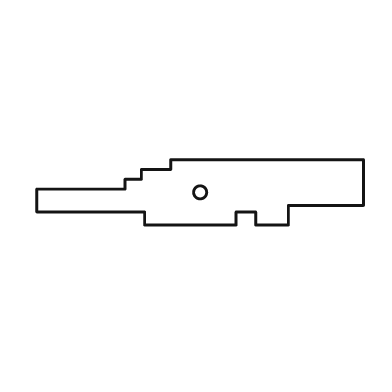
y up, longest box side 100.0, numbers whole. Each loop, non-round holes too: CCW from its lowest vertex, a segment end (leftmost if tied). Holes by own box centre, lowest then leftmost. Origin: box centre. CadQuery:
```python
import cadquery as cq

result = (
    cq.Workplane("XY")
    .moveTo(-17.0, -10.0)
    .lineTo(11.0, -10.0)
    .lineTo(11.0, -6.0)
    .lineTo(17.0, -6.0)
    .lineTo(17.0, -10.0)
    .lineTo(27.0, -10.0)
    .lineTo(27.0, -4.0)
    .lineTo(50.0, -4.0)
    .lineTo(50.0, 10.0)
    .lineTo(-9.0, 10.0)
    .lineTo(-9.0, 7.0)
    .lineTo(-18.0, 7.0)
    .lineTo(-18.0, 4.0)
    .lineTo(-23.0, 4.0)
    .lineTo(-23.0, 1.0)
    .lineTo(-50.0, 1.0)
    .lineTo(-50.0, -6.0)
    .lineTo(-17.0, -6.0)
    .close()
    .moveTo(0.0, 0.0)
    .circle(2.0)
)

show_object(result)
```